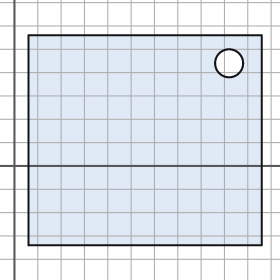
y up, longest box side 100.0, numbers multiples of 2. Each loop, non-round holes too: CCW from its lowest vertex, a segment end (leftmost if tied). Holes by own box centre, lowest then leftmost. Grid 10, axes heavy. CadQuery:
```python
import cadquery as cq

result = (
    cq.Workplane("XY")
    .moveTo(6.0, -34.0)
    .lineTo(106.0, -34.0)
    .lineTo(106.0, 56.0)
    .lineTo(6.0, 56.0)
    .close()
    .moveTo(92.0, 44.0)
    .circle(6.0)
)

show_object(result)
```